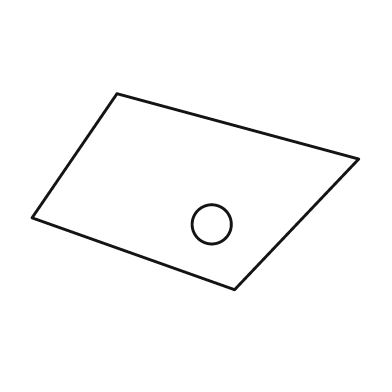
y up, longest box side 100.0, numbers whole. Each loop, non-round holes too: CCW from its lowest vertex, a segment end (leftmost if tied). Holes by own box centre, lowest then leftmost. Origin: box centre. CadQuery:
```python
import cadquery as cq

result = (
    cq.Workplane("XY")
    .moveTo(12.0, -30.0)
    .lineTo(50.0, 10.0)
    .lineTo(-24.0, 30.0)
    .lineTo(-50.0, -8.0)
    .close()
    .moveTo(5.0, -10.0)
    .circle(6.0)
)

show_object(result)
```